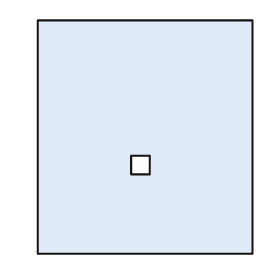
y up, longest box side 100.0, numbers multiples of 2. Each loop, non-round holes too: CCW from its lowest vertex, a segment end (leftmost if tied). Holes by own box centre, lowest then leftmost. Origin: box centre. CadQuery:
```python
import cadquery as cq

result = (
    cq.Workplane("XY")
    .moveTo(-46.0, -50.0)
    .lineTo(46.0, -50.0)
    .lineTo(46.0, 50.0)
    .lineTo(-46.0, 50.0)
    .close()
    .moveTo(-6.0, -16.0)
    .lineTo(2.0, -16.0)
    .lineTo(2.0, -8.0)
    .lineTo(-6.0, -8.0)
    .close()
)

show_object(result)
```